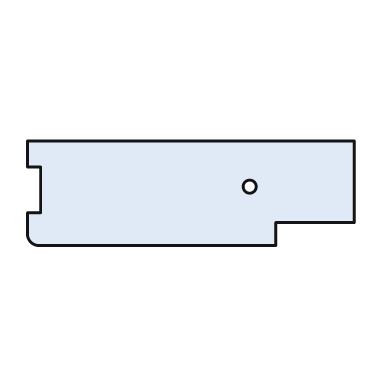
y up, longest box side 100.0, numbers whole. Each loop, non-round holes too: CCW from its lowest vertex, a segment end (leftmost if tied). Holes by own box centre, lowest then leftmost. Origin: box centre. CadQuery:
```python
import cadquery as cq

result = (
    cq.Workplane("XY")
    .moveTo(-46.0, -16.0)
    .lineTo(26.0, -16.0)
    .lineTo(26.0, -9.0)
    .lineTo(50.0, -9.0)
    .lineTo(50.0, 16.0)
    .lineTo(-50.0, 16.0)
    .lineTo(-50.0, 8.0)
    .lineTo(-46.0, 8.0)
    .lineTo(-46.0, -6.0)
    .lineTo(-50.0, -6.0)
    .lineTo(-50.0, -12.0)
    .threePointArc((-49.0, -15.0), (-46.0, -16.0))
    .close()
    .moveTo(18.0, 2.0)
    .circle(2.0)
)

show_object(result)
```